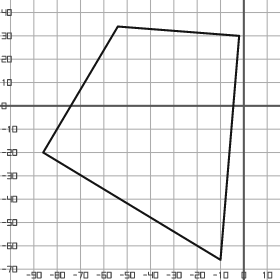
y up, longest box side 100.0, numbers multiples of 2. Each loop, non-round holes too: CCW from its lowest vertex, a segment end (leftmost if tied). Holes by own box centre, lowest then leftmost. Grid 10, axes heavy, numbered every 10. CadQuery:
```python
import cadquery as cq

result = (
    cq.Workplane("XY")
    .moveTo(-10.0, -66.0)
    .lineTo(-2.0, 30.0)
    .lineTo(-54.0, 34.0)
    .lineTo(-86.0, -20.0)
    .close()
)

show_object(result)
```